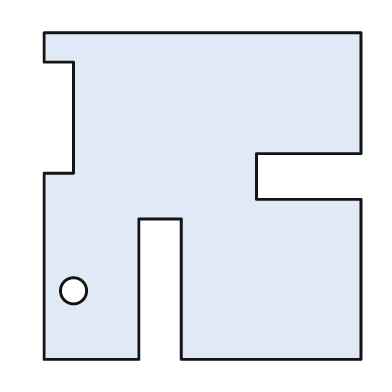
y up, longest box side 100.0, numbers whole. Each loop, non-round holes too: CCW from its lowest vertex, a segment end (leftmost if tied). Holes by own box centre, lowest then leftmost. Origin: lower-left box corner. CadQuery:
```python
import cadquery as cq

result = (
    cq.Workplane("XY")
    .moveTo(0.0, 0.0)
    .lineTo(29.0, 0.0)
    .lineTo(29.0, 43.0)
    .lineTo(42.0, 43.0)
    .lineTo(42.0, 0.0)
    .lineTo(97.0, 0.0)
    .lineTo(97.0, 49.0)
    .lineTo(65.0, 49.0)
    .lineTo(65.0, 63.0)
    .lineTo(97.0, 63.0)
    .lineTo(97.0, 100.0)
    .lineTo(0.0, 100.0)
    .lineTo(0.0, 91.0)
    .lineTo(9.0, 91.0)
    .lineTo(9.0, 57.0)
    .lineTo(0.0, 57.0)
    .close()
    .moveTo(9.0, 21.0)
    .circle(4.0)
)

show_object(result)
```